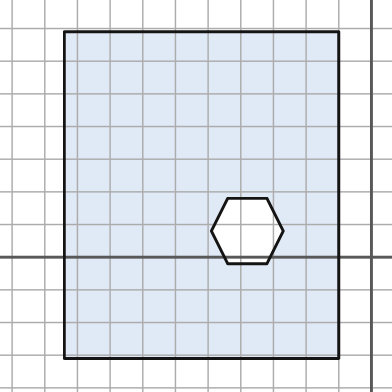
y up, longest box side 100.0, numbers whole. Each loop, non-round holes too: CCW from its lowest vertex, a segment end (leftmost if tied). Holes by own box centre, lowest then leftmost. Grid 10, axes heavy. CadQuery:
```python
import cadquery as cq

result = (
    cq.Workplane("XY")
    .moveTo(-94.0, -31.0)
    .lineTo(-10.0, -31.0)
    .lineTo(-10.0, 69.0)
    .lineTo(-94.0, 69.0)
    .close()
    .moveTo(-44.0, -2.0)
    .lineTo(-32.0, -2.0)
    .lineTo(-27.0, 8.0)
    .lineTo(-32.0, 18.0)
    .lineTo(-44.0, 18.0)
    .lineTo(-49.0, 8.0)
    .close()
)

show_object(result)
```